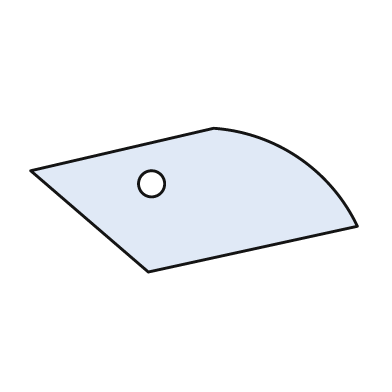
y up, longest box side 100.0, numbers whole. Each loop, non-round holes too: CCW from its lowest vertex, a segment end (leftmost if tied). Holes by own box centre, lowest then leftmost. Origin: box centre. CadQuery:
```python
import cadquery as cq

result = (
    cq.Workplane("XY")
    .moveTo(-14.0, -22.0)
    .lineTo(50.0, -8.0)
    .threePointArc((32.0, 13.0), (6.0, 22.0))
    .lineTo(-50.0, 9.0)
    .close()
    .moveTo(-13.0, 5.0)
    .circle(4.0)
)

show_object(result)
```